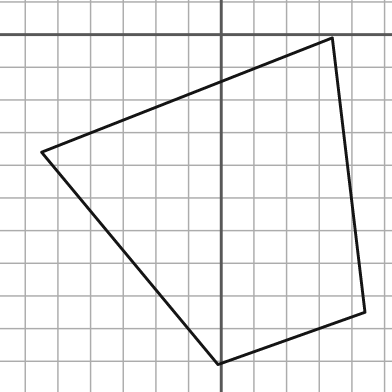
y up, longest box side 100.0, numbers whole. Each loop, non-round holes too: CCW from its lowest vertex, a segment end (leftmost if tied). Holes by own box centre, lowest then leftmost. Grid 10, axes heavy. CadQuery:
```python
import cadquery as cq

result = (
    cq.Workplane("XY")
    .moveTo(-1.0, -101.0)
    .lineTo(44.0, -85.0)
    .lineTo(34.0, -1.0)
    .lineTo(-55.0, -36.0)
    .close()
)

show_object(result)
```